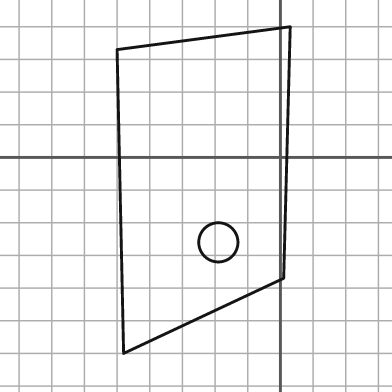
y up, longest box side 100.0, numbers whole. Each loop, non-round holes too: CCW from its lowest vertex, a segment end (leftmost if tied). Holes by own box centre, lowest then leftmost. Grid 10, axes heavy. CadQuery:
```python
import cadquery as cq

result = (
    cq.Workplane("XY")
    .moveTo(-48.0, -60.0)
    .lineTo(1.0, -37.0)
    .lineTo(3.0, 40.0)
    .lineTo(-50.0, 33.0)
    .close()
    .moveTo(-19.0, -26.0)
    .circle(6.0)
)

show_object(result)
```